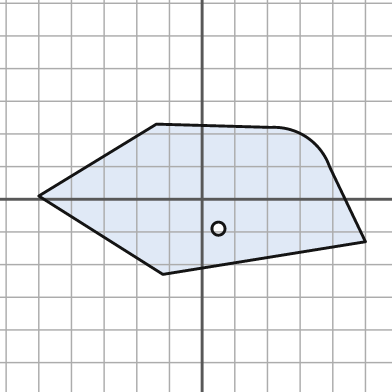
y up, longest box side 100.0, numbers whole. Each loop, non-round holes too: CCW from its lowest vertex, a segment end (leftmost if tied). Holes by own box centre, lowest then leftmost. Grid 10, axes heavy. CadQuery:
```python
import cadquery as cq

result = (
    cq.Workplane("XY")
    .moveTo(-12.0, -23.0)
    .lineTo(50.0, -13.0)
    .lineTo(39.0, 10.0)
    .threePointArc((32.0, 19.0), (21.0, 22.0))
    .lineTo(-14.0, 23.0)
    .lineTo(-50.0, 1.0)
    .close()
    .moveTo(5.0, -9.0)
    .circle(2.0)
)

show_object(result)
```